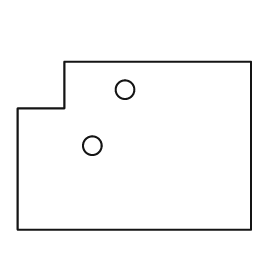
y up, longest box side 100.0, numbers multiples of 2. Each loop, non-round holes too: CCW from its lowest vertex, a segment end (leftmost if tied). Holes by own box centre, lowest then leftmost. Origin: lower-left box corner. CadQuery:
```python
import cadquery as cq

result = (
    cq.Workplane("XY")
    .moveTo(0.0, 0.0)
    .lineTo(100.0, 0.0)
    .lineTo(100.0, 72.0)
    .lineTo(20.0, 72.0)
    .lineTo(20.0, 52.0)
    .lineTo(0.0, 52.0)
    .close()
    .moveTo(32.0, 36.0)
    .circle(4.0)
    .moveTo(46.0, 60.0)
    .circle(4.0)
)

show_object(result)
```